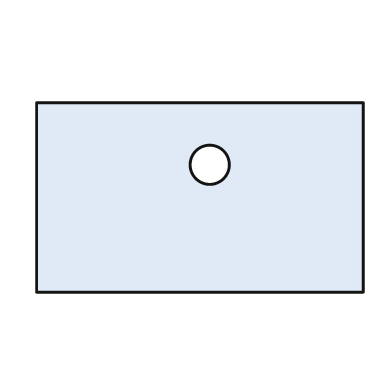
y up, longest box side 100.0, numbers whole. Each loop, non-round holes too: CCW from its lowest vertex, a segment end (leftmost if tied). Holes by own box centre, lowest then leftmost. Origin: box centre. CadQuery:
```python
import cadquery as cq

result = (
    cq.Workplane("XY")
    .moveTo(-50.0, -29.0)
    .lineTo(50.0, -29.0)
    .lineTo(50.0, 29.0)
    .lineTo(-50.0, 29.0)
    .close()
    .moveTo(3.0, 10.0)
    .circle(6.0)
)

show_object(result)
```